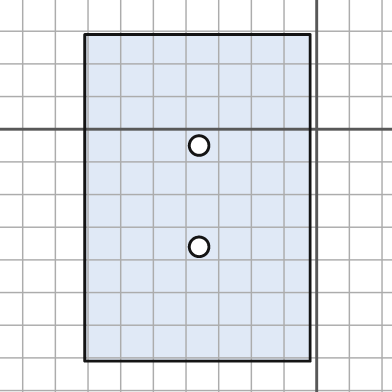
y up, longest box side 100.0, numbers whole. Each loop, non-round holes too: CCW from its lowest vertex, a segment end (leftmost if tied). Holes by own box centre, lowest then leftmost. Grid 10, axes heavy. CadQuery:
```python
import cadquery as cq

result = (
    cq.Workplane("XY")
    .moveTo(-71.0, -71.0)
    .lineTo(-2.0, -71.0)
    .lineTo(-2.0, 29.0)
    .lineTo(-71.0, 29.0)
    .close()
    .moveTo(-36.0, -36.0)
    .circle(3.0)
    .moveTo(-36.0, -5.0)
    .circle(3.0)
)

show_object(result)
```